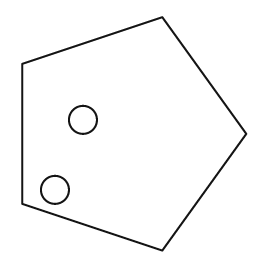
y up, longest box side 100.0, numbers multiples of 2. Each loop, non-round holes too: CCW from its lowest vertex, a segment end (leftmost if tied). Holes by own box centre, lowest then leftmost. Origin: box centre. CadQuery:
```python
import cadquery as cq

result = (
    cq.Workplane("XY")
    .moveTo(12.0, -50.0)
    .lineTo(48.0, 0.0)
    .lineTo(12.0, 50.0)
    .lineTo(-48.0, 30.0)
    .lineTo(-48.0, -30.0)
    .close()
    .moveTo(-34.0, -24.0)
    .circle(6.0)
    .moveTo(-22.0, 6.0)
    .circle(6.0)
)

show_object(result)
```